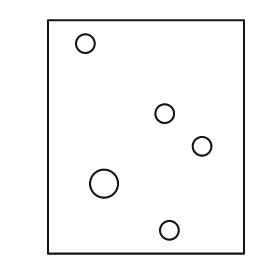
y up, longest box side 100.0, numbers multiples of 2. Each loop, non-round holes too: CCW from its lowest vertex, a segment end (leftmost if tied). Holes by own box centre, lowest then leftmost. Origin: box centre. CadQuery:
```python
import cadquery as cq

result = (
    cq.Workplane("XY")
    .moveTo(-42.0, -50.0)
    .lineTo(42.0, -50.0)
    .lineTo(42.0, 50.0)
    .lineTo(-42.0, 50.0)
    .close()
    .moveTo(10.0, -40.0)
    .circle(4.0)
    .moveTo(-18.0, -20.0)
    .circle(6.0)
    .moveTo(24.0, -4.0)
    .circle(4.0)
    .moveTo(8.0, 10.0)
    .circle(4.0)
    .moveTo(-26.0, 40.0)
    .circle(4.0)
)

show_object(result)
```